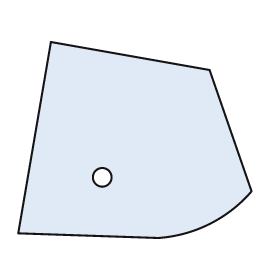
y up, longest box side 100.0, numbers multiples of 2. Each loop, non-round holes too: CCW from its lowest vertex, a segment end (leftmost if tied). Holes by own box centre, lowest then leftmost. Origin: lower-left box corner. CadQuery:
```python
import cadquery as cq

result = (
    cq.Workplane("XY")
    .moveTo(60.0, 0.0)
    .threePointArc((82.0, 6.0), (100.0, 20.0))
    .lineTo(82.0, 72.0)
    .lineTo(14.0, 84.0)
    .lineTo(0.0, 2.0)
    .close()
    .moveTo(36.0, 26.0)
    .circle(4.0)
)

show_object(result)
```